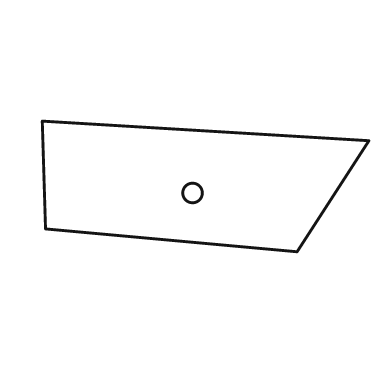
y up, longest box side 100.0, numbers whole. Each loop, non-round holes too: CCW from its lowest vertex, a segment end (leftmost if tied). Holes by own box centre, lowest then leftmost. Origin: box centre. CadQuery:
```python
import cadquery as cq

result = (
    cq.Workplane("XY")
    .moveTo(28.0, -20.0)
    .lineTo(50.0, 14.0)
    .lineTo(-50.0, 20.0)
    .lineTo(-49.0, -13.0)
    .close()
    .moveTo(-4.0, -2.0)
    .circle(3.0)
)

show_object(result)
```